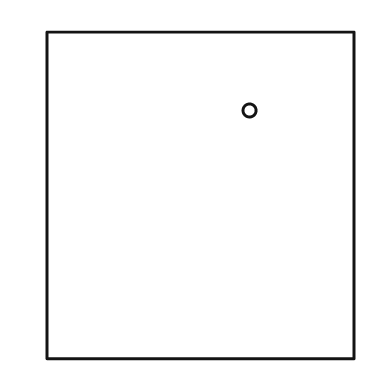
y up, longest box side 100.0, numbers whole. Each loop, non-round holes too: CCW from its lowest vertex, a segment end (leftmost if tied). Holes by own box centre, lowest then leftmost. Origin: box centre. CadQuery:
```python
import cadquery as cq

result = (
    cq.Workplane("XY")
    .moveTo(-47.0, -50.0)
    .lineTo(47.0, -50.0)
    .lineTo(47.0, 50.0)
    .lineTo(-47.0, 50.0)
    .close()
    .moveTo(15.0, 26.0)
    .circle(2.0)
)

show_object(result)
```